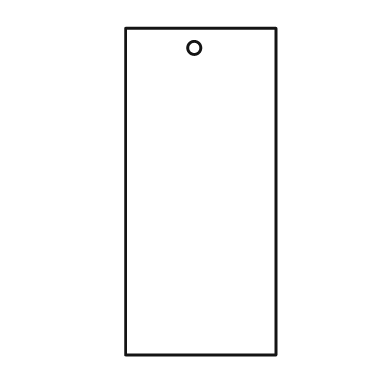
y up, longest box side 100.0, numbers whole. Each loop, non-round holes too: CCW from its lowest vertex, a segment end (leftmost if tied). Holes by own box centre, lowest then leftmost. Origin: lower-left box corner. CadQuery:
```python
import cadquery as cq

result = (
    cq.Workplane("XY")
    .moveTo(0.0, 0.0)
    .lineTo(46.0, 0.0)
    .lineTo(46.0, 100.0)
    .lineTo(0.0, 100.0)
    .close()
    .moveTo(21.0, 94.0)
    .circle(2.0)
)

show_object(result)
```